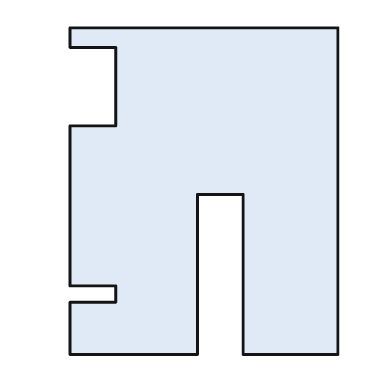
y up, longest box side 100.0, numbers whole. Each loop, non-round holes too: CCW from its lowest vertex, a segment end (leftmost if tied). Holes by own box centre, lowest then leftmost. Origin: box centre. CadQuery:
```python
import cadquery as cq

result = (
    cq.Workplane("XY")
    .moveTo(-41.0, -50.0)
    .lineTo(-2.0, -50.0)
    .lineTo(-2.0, -1.0)
    .lineTo(12.0, -1.0)
    .lineTo(12.0, -50.0)
    .lineTo(41.0, -50.0)
    .lineTo(41.0, 50.0)
    .lineTo(-41.0, 50.0)
    .lineTo(-41.0, 44.0)
    .lineTo(-27.0, 44.0)
    .lineTo(-27.0, 20.0)
    .lineTo(-41.0, 20.0)
    .lineTo(-41.0, -29.0)
    .lineTo(-27.0, -29.0)
    .lineTo(-27.0, -34.0)
    .lineTo(-41.0, -34.0)
    .close()
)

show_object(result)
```